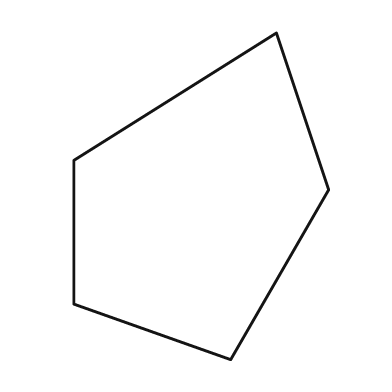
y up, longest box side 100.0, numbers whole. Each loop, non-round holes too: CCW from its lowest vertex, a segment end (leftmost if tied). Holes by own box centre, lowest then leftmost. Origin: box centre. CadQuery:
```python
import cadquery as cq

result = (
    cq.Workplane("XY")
    .moveTo(9.0, -50.0)
    .lineTo(39.0, 2.0)
    .lineTo(23.0, 50.0)
    .lineTo(-39.0, 11.0)
    .lineTo(-39.0, -33.0)
    .close()
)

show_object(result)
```